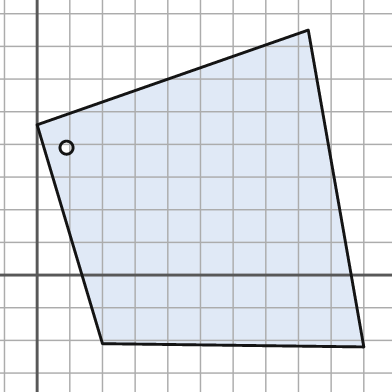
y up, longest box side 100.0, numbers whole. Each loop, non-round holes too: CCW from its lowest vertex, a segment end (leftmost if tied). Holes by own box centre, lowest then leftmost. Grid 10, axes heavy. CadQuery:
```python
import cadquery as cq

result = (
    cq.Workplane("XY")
    .moveTo(100.0, -22.0)
    .lineTo(83.0, 75.0)
    .lineTo(0.0, 46.0)
    .lineTo(20.0, -21.0)
    .close()
    .moveTo(9.0, 39.0)
    .circle(2.0)
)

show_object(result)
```